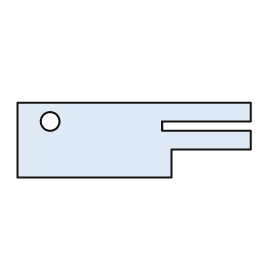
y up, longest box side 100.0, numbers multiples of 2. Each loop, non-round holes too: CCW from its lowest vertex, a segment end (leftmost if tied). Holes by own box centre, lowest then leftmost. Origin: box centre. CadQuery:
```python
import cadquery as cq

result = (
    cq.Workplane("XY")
    .moveTo(-50.0, -16.0)
    .lineTo(16.0, -16.0)
    .lineTo(16.0, -4.0)
    .lineTo(50.0, -4.0)
    .lineTo(50.0, 4.0)
    .lineTo(12.0, 4.0)
    .lineTo(12.0, 8.0)
    .lineTo(50.0, 8.0)
    .lineTo(50.0, 16.0)
    .lineTo(-50.0, 16.0)
    .close()
    .moveTo(-36.0, 8.0)
    .circle(4.0)
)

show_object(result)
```